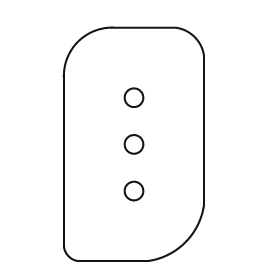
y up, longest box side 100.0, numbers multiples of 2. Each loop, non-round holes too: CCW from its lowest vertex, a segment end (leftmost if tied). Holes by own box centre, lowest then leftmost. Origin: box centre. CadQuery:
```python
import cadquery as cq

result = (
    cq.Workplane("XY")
    .moveTo(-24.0, -50.0)
    .lineTo(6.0, -50.0)
    .threePointArc((22.0, -42.0), (30.0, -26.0))
    .lineTo(30.0, 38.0)
    .threePointArc((26.0, 46.0), (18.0, 50.0))
    .lineTo(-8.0, 50.0)
    .threePointArc((-24.0, 44.0), (-30.0, 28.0))
    .lineTo(-30.0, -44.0)
    .threePointArc((-28.0, -48.0), (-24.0, -50.0))
    .close()
    .moveTo(0.0, -20.0)
    .circle(4.0)
    .moveTo(0.0, 0.0)
    .circle(4.0)
    .moveTo(0.0, 20.0)
    .circle(4.0)
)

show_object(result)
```